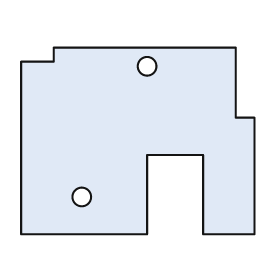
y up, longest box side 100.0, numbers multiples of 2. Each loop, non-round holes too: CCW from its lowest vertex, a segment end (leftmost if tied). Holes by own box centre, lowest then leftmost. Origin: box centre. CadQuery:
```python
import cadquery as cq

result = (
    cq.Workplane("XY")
    .moveTo(-50.0, -40.0)
    .lineTo(4.0, -40.0)
    .lineTo(4.0, -6.0)
    .lineTo(28.0, -6.0)
    .lineTo(28.0, -40.0)
    .lineTo(50.0, -40.0)
    .lineTo(50.0, 10.0)
    .lineTo(42.0, 10.0)
    .lineTo(42.0, 40.0)
    .lineTo(-36.0, 40.0)
    .lineTo(-36.0, 34.0)
    .lineTo(-50.0, 34.0)
    .close()
    .moveTo(-24.0, -24.0)
    .circle(4.0)
    .moveTo(4.0, 32.0)
    .circle(4.0)
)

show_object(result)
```